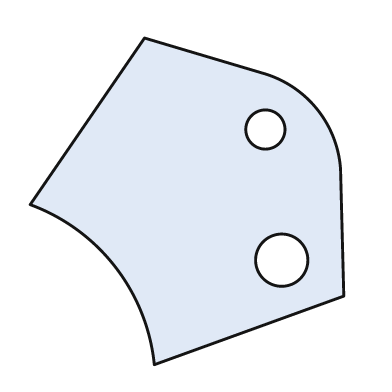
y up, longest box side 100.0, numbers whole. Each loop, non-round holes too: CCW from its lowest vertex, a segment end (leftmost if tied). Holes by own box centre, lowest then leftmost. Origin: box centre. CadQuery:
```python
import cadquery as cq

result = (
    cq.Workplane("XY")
    .moveTo(-10.0, -50.0)
    .lineTo(48.0, -29.0)
    .lineTo(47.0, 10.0)
    .threePointArc((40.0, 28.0), (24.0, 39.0))
    .lineTo(-13.0, 50.0)
    .lineTo(-48.0, -1.0)
    .threePointArc((-22.0, -20.0), (-10.0, -50.0))
    .close()
    .moveTo(29.0, -18.0)
    .circle(8.0)
    .moveTo(24.0, 22.0)
    .circle(6.0)
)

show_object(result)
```